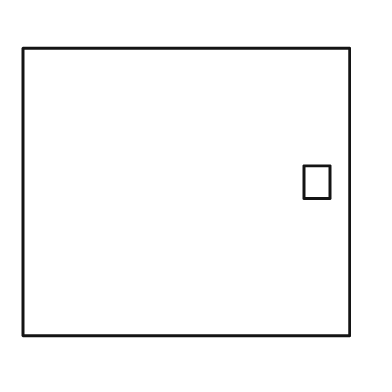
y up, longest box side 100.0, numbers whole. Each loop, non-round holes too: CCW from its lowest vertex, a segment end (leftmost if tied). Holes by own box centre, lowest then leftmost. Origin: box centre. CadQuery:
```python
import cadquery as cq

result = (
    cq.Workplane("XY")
    .moveTo(-50.0, -44.0)
    .lineTo(50.0, -44.0)
    .lineTo(50.0, 44.0)
    .lineTo(-50.0, 44.0)
    .close()
    .moveTo(36.0, -2.0)
    .lineTo(44.0, -2.0)
    .lineTo(44.0, 8.0)
    .lineTo(36.0, 8.0)
    .close()
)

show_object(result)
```